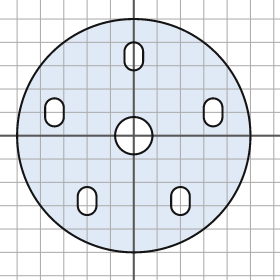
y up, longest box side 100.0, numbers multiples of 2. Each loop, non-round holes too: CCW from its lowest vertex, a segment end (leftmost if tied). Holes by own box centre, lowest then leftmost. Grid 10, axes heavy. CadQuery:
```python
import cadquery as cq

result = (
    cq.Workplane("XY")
    .moveTo(0.0, 0.0)
    .circle(50.0)
    .moveTo(-24.0, -30.0)
    .threePointArc((-20.0, -34.0), (-16.0, -30.0))
    .lineTo(-16.0, -26.0)
    .threePointArc((-20.0, -22.0), (-24.0, -26.0))
    .close()
    .moveTo(16.0, -30.0)
    .threePointArc((20.0, -34.0), (24.0, -30.0))
    .lineTo(24.0, -26.0)
    .threePointArc((20.0, -22.0), (16.0, -26.0))
    .close()
    .moveTo(0.0, 0.0)
    .circle(8.0)
    .moveTo(-38.0, 8.0)
    .threePointArc((-34.0, 4.0), (-30.0, 8.0))
    .lineTo(-30.0, 12.0)
    .threePointArc((-34.0, 16.0), (-38.0, 12.0))
    .close()
    .moveTo(30.0, 8.0)
    .threePointArc((34.0, 4.0), (38.0, 8.0))
    .lineTo(38.0, 12.0)
    .threePointArc((34.0, 16.0), (30.0, 12.0))
    .close()
    .moveTo(-4.0, 32.0)
    .threePointArc((0.0, 28.0), (4.0, 32.0))
    .lineTo(4.0, 36.0)
    .threePointArc((0.0, 40.0), (-4.0, 36.0))
    .close()
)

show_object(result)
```